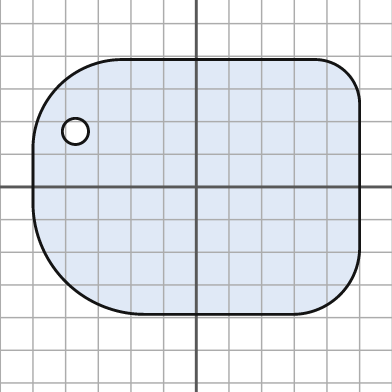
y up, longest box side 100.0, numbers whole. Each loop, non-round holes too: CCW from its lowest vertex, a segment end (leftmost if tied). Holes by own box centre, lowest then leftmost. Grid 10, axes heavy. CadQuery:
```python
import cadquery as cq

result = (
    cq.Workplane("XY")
    .moveTo(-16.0, -39.0)
    .lineTo(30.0, -39.0)
    .threePointArc((44.0, -33.0), (50.0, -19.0))
    .lineTo(50.0, 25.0)
    .threePointArc((46.0, 35.0), (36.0, 39.0))
    .lineTo(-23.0, 39.0)
    .threePointArc((-42.0, 31.0), (-50.0, 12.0))
    .lineTo(-50.0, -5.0)
    .threePointArc((-40.0, -29.0), (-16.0, -39.0))
    .close()
    .moveTo(-37.0, 17.0)
    .circle(4.0)
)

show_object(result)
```